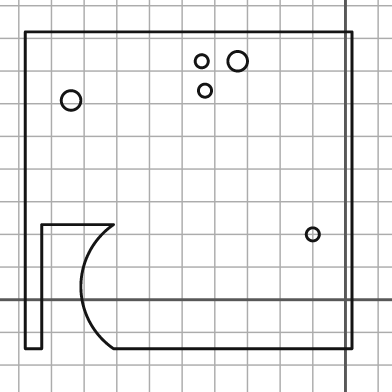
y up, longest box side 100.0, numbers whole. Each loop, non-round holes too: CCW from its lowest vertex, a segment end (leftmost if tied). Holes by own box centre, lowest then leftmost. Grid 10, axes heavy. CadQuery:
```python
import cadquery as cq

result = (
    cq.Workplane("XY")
    .moveTo(-98.0, -15.0)
    .lineTo(-93.0, -15.0)
    .lineTo(-93.0, 23.0)
    .lineTo(-71.0, 23.0)
    .threePointArc((-81.0, 4.0), (-71.0, -15.0))
    .lineTo(2.0, -15.0)
    .lineTo(2.0, 82.0)
    .lineTo(-98.0, 82.0)
    .close()
    .moveTo(-10.0, 20.0)
    .circle(2.0)
    .moveTo(-84.0, 61.0)
    .circle(3.0)
    .moveTo(-43.0, 64.0)
    .circle(2.0)
    .moveTo(-44.0, 73.0)
    .circle(2.0)
    .moveTo(-33.0, 73.0)
    .circle(3.0)
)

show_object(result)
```